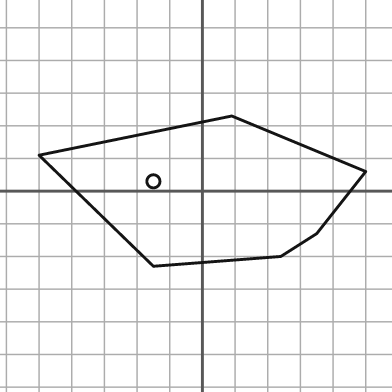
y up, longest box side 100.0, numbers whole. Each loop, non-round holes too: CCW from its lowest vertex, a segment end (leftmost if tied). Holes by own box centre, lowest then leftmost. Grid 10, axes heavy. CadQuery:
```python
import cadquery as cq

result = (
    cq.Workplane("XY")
    .moveTo(-15.0, -23.0)
    .lineTo(24.0, -20.0)
    .lineTo(35.0, -13.0)
    .lineTo(50.0, 6.0)
    .lineTo(9.0, 23.0)
    .lineTo(-50.0, 11.0)
    .close()
    .moveTo(-15.0, 3.0)
    .circle(2.0)
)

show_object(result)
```